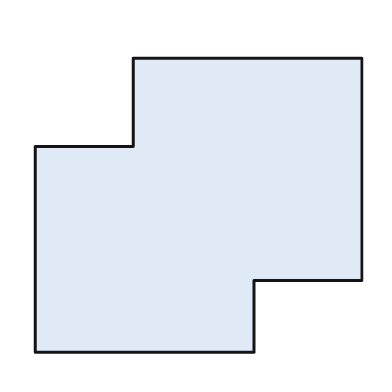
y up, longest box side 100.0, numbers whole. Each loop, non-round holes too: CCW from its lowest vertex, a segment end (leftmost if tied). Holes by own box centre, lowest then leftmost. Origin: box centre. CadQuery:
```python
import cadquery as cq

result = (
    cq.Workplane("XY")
    .moveTo(-50.0, -45.0)
    .lineTo(17.0, -45.0)
    .lineTo(17.0, -23.0)
    .lineTo(50.0, -23.0)
    .lineTo(50.0, 45.0)
    .lineTo(-20.0, 45.0)
    .lineTo(-20.0, 18.0)
    .lineTo(-50.0, 18.0)
    .close()
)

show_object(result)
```